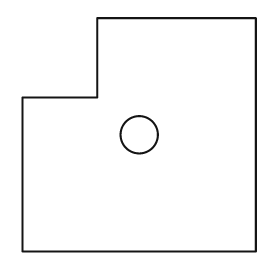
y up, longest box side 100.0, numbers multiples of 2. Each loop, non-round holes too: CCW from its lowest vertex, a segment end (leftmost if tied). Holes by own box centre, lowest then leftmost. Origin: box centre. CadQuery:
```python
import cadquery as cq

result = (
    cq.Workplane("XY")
    .moveTo(-50.0, -50.0)
    .lineTo(50.0, -50.0)
    .lineTo(50.0, 50.0)
    .lineTo(-18.0, 50.0)
    .lineTo(-18.0, 16.0)
    .lineTo(-50.0, 16.0)
    .close()
    .moveTo(0.0, 0.0)
    .circle(8.0)
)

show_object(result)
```